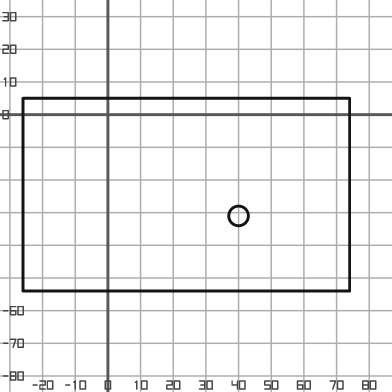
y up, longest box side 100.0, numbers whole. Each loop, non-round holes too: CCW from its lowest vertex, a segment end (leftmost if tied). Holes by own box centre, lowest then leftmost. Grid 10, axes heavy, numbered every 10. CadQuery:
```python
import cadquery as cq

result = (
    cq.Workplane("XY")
    .moveTo(-26.0, -54.0)
    .lineTo(74.0, -54.0)
    .lineTo(74.0, 5.0)
    .lineTo(-26.0, 5.0)
    .close()
    .moveTo(40.0, -31.0)
    .circle(3.0)
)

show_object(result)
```